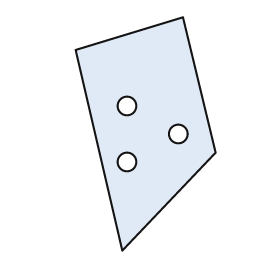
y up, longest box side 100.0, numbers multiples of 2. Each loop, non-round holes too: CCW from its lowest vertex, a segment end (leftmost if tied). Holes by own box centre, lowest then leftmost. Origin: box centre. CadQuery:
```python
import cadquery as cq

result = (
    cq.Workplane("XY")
    .moveTo(-10.0, -50.0)
    .lineTo(30.0, -8.0)
    .lineTo(16.0, 50.0)
    .lineTo(-30.0, 36.0)
    .close()
    .moveTo(-8.0, -12.0)
    .circle(4.0)
    .moveTo(14.0, 0.0)
    .circle(4.0)
    .moveTo(-8.0, 12.0)
    .circle(4.0)
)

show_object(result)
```